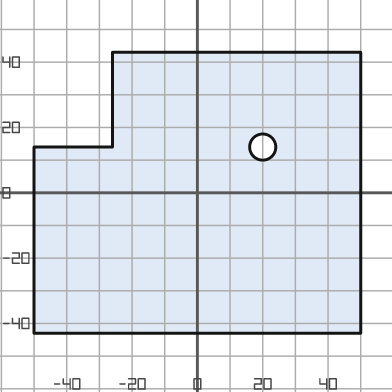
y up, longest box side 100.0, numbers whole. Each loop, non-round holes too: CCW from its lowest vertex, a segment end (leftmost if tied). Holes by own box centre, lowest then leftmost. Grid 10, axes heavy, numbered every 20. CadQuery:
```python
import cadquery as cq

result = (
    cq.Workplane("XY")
    .moveTo(-50.0, -43.0)
    .lineTo(50.0, -43.0)
    .lineTo(50.0, 43.0)
    .lineTo(-26.0, 43.0)
    .lineTo(-26.0, 14.0)
    .lineTo(-50.0, 14.0)
    .close()
    .moveTo(20.0, 14.0)
    .circle(4.0)
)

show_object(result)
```